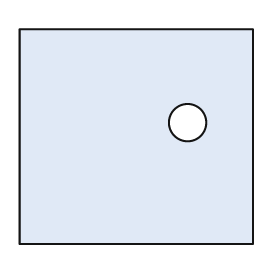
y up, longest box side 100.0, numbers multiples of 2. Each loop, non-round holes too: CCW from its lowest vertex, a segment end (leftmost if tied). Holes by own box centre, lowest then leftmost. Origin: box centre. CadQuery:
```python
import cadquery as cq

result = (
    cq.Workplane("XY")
    .moveTo(-50.0, -46.0)
    .lineTo(50.0, -46.0)
    .lineTo(50.0, 46.0)
    .lineTo(-50.0, 46.0)
    .close()
    .moveTo(22.0, 6.0)
    .circle(8.0)
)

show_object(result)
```